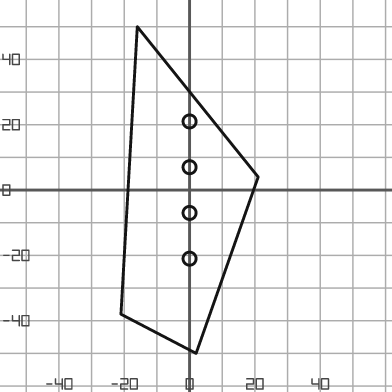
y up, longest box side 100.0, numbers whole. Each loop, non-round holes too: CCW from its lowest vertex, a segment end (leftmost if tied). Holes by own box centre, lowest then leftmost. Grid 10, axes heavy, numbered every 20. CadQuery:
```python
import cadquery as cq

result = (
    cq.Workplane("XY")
    .moveTo(2.0, -50.0)
    .lineTo(21.0, 4.0)
    .lineTo(-16.0, 50.0)
    .lineTo(-21.0, -38.0)
    .close()
    .moveTo(0.0, -21.0)
    .circle(2.0)
    .moveTo(0.0, -7.0)
    .circle(2.0)
    .moveTo(0.0, 7.0)
    .circle(2.0)
    .moveTo(0.0, 21.0)
    .circle(2.0)
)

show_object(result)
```